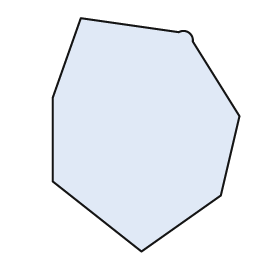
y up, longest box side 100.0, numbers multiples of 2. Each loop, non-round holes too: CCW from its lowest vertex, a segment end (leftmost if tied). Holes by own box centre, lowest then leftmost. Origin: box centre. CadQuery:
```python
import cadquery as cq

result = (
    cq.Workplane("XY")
    .moveTo(-2.0, -50.0)
    .lineTo(32.0, -26.0)
    .lineTo(40.0, 8.0)
    .lineTo(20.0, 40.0)
    .threePointArc((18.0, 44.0), (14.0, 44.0))
    .lineTo(-28.0, 50.0)
    .lineTo(-40.0, 16.0)
    .lineTo(-40.0, -20.0)
    .close()
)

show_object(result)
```